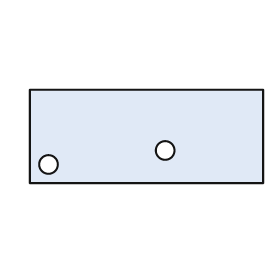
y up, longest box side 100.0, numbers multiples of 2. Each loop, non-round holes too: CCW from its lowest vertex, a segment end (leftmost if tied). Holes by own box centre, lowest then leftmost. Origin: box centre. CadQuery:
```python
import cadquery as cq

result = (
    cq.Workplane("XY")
    .moveTo(-50.0, -20.0)
    .lineTo(50.0, -20.0)
    .lineTo(50.0, 20.0)
    .lineTo(-50.0, 20.0)
    .close()
    .moveTo(-42.0, -12.0)
    .circle(4.0)
    .moveTo(8.0, -6.0)
    .circle(4.0)
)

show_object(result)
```